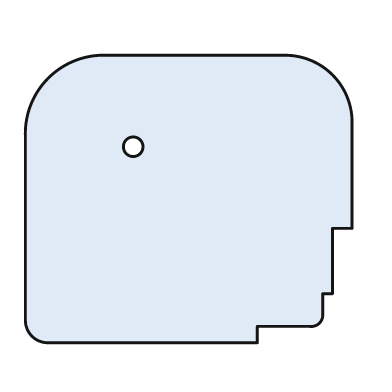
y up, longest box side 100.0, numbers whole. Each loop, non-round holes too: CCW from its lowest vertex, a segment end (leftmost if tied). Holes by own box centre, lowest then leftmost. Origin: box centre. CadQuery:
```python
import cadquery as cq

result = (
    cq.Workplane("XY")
    .moveTo(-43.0, -44.0)
    .lineTo(21.0, -44.0)
    .lineTo(21.0, -39.0)
    .lineTo(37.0, -39.0)
    .threePointArc((40.0, -38.0), (41.0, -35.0))
    .lineTo(41.0, -29.0)
    .lineTo(44.0, -29.0)
    .lineTo(44.0, -9.0)
    .lineTo(50.0, -9.0)
    .lineTo(50.0, 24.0)
    .threePointArc((44.0, 38.0), (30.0, 44.0))
    .lineTo(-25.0, 44.0)
    .threePointArc((-43.0, 37.0), (-50.0, 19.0))
    .lineTo(-50.0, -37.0)
    .threePointArc((-48.0, -42.0), (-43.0, -44.0))
    .close()
    .moveTo(-17.0, 16.0)
    .circle(3.0)
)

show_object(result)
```